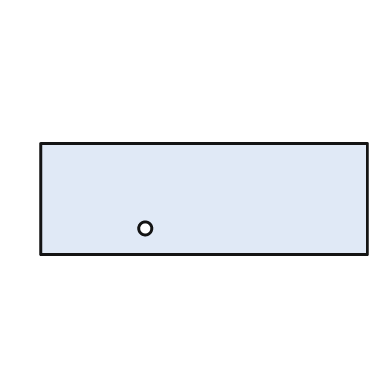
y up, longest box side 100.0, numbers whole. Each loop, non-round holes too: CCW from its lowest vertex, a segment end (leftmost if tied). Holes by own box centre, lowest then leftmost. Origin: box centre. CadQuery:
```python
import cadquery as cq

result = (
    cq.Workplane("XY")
    .moveTo(-50.0, -17.0)
    .lineTo(50.0, -17.0)
    .lineTo(50.0, 17.0)
    .lineTo(-50.0, 17.0)
    .close()
    .moveTo(-18.0, -9.0)
    .circle(2.0)
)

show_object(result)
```